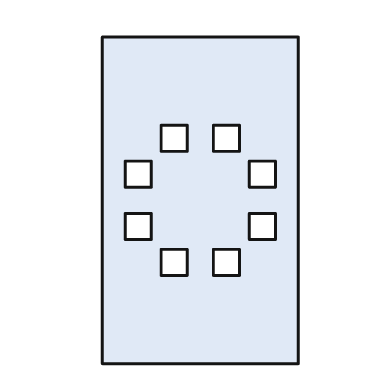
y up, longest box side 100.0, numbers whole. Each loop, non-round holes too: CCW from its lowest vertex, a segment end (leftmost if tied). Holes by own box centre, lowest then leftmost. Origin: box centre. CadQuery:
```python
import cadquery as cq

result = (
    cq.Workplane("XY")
    .moveTo(-30.0, -50.0)
    .lineTo(30.0, -50.0)
    .lineTo(30.0, 50.0)
    .lineTo(-30.0, 50.0)
    .close()
    .moveTo(-12.0, -23.0)
    .lineTo(-4.0, -23.0)
    .lineTo(-4.0, -15.0)
    .lineTo(-12.0, -15.0)
    .close()
    .moveTo(4.0, -23.0)
    .lineTo(12.0, -23.0)
    .lineTo(12.0, -15.0)
    .lineTo(4.0, -15.0)
    .close()
    .moveTo(-23.0, -12.0)
    .lineTo(-15.0, -12.0)
    .lineTo(-15.0, -4.0)
    .lineTo(-23.0, -4.0)
    .close()
    .moveTo(15.0, -12.0)
    .lineTo(23.0, -12.0)
    .lineTo(23.0, -4.0)
    .lineTo(15.0, -4.0)
    .close()
    .moveTo(-23.0, 4.0)
    .lineTo(-15.0, 4.0)
    .lineTo(-15.0, 12.0)
    .lineTo(-23.0, 12.0)
    .close()
    .moveTo(15.0, 4.0)
    .lineTo(23.0, 4.0)
    .lineTo(23.0, 12.0)
    .lineTo(15.0, 12.0)
    .close()
    .moveTo(-12.0, 15.0)
    .lineTo(-4.0, 15.0)
    .lineTo(-4.0, 23.0)
    .lineTo(-12.0, 23.0)
    .close()
    .moveTo(4.0, 15.0)
    .lineTo(12.0, 15.0)
    .lineTo(12.0, 23.0)
    .lineTo(4.0, 23.0)
    .close()
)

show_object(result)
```